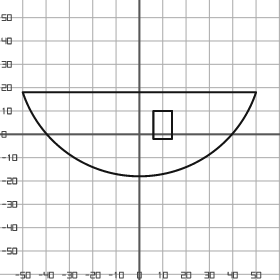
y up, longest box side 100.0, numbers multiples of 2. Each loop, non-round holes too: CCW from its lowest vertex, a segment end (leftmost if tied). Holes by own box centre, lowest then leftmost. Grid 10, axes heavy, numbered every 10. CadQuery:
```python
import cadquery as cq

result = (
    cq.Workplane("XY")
    .moveTo(-50.0, 18.0)
    .threePointArc((0.0, -18.0), (50.0, 18.0))
    .close()
    .moveTo(6.0, -2.0)
    .lineTo(14.0, -2.0)
    .lineTo(14.0, 10.0)
    .lineTo(6.0, 10.0)
    .close()
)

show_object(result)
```